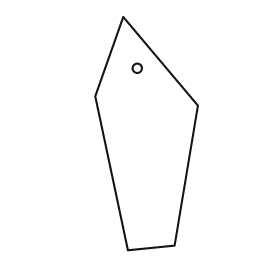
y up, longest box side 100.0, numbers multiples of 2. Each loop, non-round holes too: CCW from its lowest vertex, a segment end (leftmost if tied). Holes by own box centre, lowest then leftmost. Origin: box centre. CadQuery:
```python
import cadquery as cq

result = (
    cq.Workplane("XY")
    .moveTo(-8.0, -50.0)
    .lineTo(12.0, -48.0)
    .lineTo(22.0, 12.0)
    .lineTo(-10.0, 50.0)
    .lineTo(-22.0, 16.0)
    .close()
    .moveTo(-4.0, 28.0)
    .circle(2.0)
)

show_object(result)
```